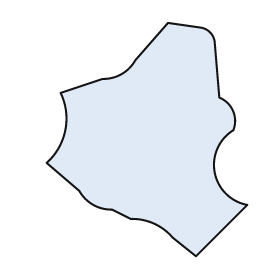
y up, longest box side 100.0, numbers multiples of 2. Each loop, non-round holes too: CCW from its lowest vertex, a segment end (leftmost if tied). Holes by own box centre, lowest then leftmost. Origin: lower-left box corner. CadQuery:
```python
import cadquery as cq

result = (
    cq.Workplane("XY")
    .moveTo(64.0, 0.0)
    .lineTo(86.0, 22.0)
    .threePointArc((72.0, 36.0), (80.0, 54.0))
    .threePointArc((80.0, 62.0), (74.0, 68.0))
    .lineTo(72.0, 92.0)
    .threePointArc((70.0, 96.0), (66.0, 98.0))
    .lineTo(52.0, 100.0)
    .lineTo(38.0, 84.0)
    .threePointArc((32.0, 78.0), (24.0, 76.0))
    .lineTo(6.0, 70.0)
    .threePointArc((8.0, 54.0), (0.0, 40.0))
    .lineTo(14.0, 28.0)
    .threePointArc((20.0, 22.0), (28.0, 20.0))
    .lineTo(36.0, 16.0)
    .threePointArc((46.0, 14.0), (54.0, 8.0))
    .close()
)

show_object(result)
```